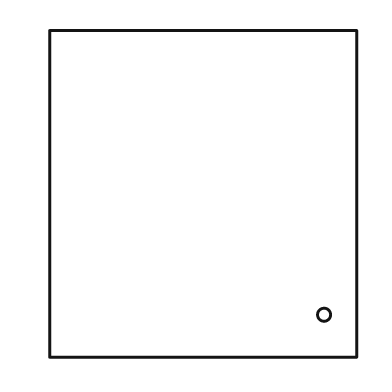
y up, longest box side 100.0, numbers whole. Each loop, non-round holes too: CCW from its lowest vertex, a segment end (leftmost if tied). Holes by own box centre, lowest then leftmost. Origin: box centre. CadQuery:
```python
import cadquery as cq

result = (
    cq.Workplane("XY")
    .moveTo(-47.0, -50.0)
    .lineTo(47.0, -50.0)
    .lineTo(47.0, 50.0)
    .lineTo(-47.0, 50.0)
    .close()
    .moveTo(37.0, -37.0)
    .circle(2.0)
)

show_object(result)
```